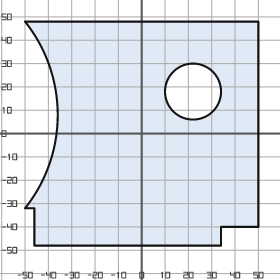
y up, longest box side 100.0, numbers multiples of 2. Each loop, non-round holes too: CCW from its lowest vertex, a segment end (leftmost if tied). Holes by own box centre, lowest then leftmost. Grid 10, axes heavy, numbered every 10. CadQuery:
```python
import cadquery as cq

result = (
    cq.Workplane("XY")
    .moveTo(-46.0, -48.0)
    .lineTo(34.0, -48.0)
    .lineTo(34.0, -40.0)
    .lineTo(50.0, -40.0)
    .lineTo(50.0, 48.0)
    .lineTo(-50.0, 48.0)
    .threePointArc((-36.0, 8.0), (-50.0, -32.0))
    .lineTo(-46.0, -32.0)
    .close()
    .moveTo(22.0, 18.0)
    .circle(12.0)
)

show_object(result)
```